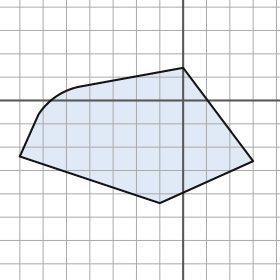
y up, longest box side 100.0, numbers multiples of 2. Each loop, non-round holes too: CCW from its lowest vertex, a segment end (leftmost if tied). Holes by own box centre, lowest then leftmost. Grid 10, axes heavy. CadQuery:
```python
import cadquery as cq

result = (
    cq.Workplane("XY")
    .moveTo(-10.0, -44.0)
    .lineTo(30.0, -26.0)
    .lineTo(0.0, 14.0)
    .lineTo(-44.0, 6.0)
    .threePointArc((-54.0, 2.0), (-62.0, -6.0))
    .lineTo(-70.0, -24.0)
    .close()
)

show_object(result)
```